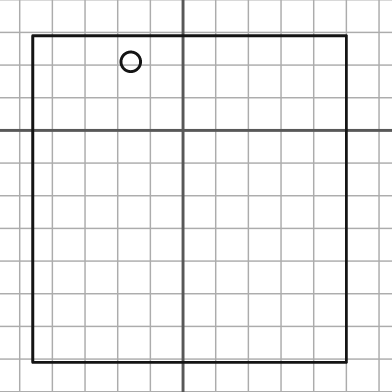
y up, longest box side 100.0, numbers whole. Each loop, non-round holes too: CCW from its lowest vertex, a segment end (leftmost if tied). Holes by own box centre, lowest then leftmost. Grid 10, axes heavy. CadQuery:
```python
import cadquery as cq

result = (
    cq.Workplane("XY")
    .moveTo(-46.0, -71.0)
    .lineTo(50.0, -71.0)
    .lineTo(50.0, 29.0)
    .lineTo(-46.0, 29.0)
    .close()
    .moveTo(-16.0, 21.0)
    .circle(3.0)
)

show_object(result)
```